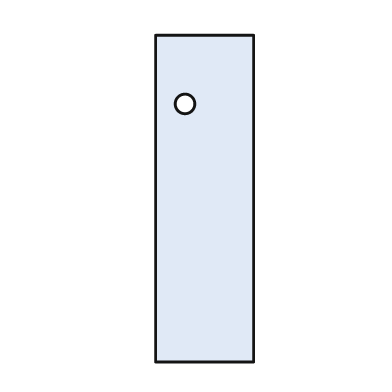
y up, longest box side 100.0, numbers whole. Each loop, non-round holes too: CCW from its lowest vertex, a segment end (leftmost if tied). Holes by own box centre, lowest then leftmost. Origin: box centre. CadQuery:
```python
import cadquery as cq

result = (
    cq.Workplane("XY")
    .moveTo(-15.0, -50.0)
    .lineTo(15.0, -50.0)
    .lineTo(15.0, 50.0)
    .lineTo(-15.0, 50.0)
    .close()
    .moveTo(-6.0, 29.0)
    .circle(3.0)
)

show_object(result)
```